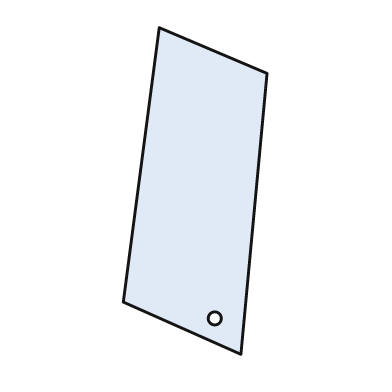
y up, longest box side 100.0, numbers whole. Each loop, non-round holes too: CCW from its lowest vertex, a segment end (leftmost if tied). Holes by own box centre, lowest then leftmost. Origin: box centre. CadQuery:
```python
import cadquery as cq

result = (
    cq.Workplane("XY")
    .moveTo(14.0, -50.0)
    .lineTo(22.0, 36.0)
    .lineTo(-11.0, 50.0)
    .lineTo(-22.0, -34.0)
    .close()
    .moveTo(6.0, -39.0)
    .circle(2.0)
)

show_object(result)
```